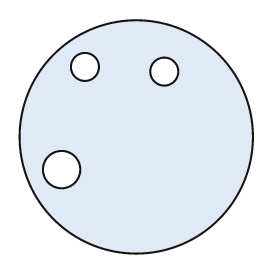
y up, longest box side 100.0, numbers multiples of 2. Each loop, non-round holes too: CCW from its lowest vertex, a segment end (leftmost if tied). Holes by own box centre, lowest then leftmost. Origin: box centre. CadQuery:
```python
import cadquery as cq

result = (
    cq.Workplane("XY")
    .moveTo(0.0, 0.0)
    .circle(50.0)
    .moveTo(-32.0, -14.0)
    .circle(8.0)
    .moveTo(12.0, 28.0)
    .circle(6.0)
    .moveTo(-22.0, 30.0)
    .circle(6.0)
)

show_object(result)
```